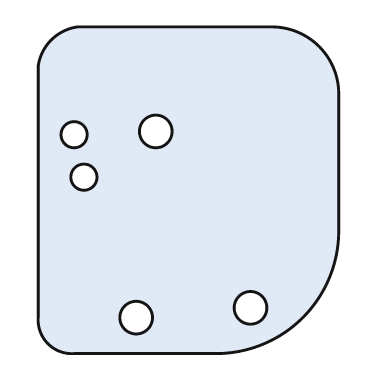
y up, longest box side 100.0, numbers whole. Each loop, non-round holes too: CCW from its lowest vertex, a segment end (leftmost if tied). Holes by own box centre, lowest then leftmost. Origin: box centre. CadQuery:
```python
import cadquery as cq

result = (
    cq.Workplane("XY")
    .moveTo(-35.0, -50.0)
    .lineTo(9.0, -50.0)
    .threePointArc((35.0, -39.0), (46.0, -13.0))
    .lineTo(46.0, 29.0)
    .threePointArc((40.0, 44.0), (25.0, 50.0))
    .lineTo(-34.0, 50.0)
    .threePointArc((-42.0, 46.0), (-46.0, 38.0))
    .lineTo(-46.0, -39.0)
    .threePointArc((-43.0, -47.0), (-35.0, -50.0))
    .close()
    .moveTo(-16.0, -39.0)
    .circle(5.0)
    .moveTo(19.0, -36.0)
    .circle(5.0)
    .moveTo(-32.0, 4.0)
    .circle(4.0)
    .moveTo(-35.0, 17.0)
    .circle(4.0)
    .moveTo(-10.0, 18.0)
    .circle(5.0)
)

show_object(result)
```